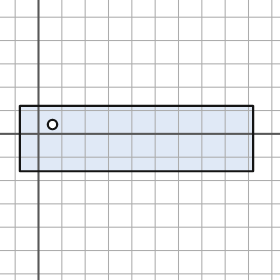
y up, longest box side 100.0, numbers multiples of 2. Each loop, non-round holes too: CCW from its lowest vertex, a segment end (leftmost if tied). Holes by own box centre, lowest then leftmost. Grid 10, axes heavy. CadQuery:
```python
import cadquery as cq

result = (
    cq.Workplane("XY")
    .moveTo(-8.0, -16.0)
    .lineTo(92.0, -16.0)
    .lineTo(92.0, 12.0)
    .lineTo(-8.0, 12.0)
    .close()
    .moveTo(6.0, 4.0)
    .circle(2.0)
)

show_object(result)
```